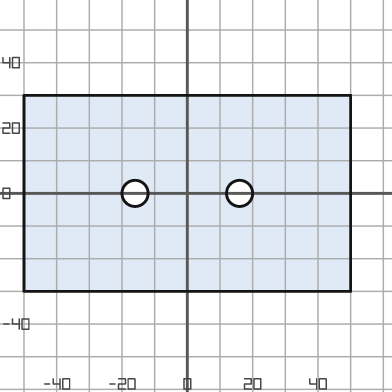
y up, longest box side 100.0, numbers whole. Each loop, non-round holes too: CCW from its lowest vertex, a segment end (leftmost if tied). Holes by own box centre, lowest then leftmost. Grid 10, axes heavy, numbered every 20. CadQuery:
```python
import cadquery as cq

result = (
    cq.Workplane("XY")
    .moveTo(-50.0, -30.0)
    .lineTo(50.0, -30.0)
    .lineTo(50.0, 30.0)
    .lineTo(-50.0, 30.0)
    .close()
    .moveTo(-16.0, 0.0)
    .circle(4.0)
    .moveTo(16.0, 0.0)
    .circle(4.0)
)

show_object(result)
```